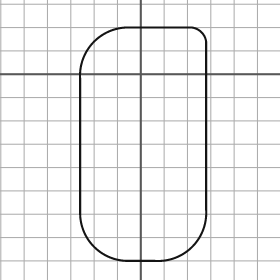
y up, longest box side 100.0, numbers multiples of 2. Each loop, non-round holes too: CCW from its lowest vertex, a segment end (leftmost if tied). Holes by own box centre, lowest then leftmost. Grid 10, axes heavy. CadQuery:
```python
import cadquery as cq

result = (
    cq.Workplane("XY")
    .moveTo(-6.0, -80.0)
    .lineTo(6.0, -80.0)
    .threePointArc((22.0, -74.0), (28.0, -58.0))
    .lineTo(28.0, 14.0)
    .threePointArc((26.0, 18.0), (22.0, 20.0))
    .lineTo(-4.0, 20.0)
    .threePointArc((-20.0, 14.0), (-26.0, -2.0))
    .lineTo(-26.0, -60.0)
    .threePointArc((-20.0, -74.0), (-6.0, -80.0))
    .close()
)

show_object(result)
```